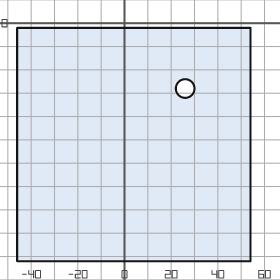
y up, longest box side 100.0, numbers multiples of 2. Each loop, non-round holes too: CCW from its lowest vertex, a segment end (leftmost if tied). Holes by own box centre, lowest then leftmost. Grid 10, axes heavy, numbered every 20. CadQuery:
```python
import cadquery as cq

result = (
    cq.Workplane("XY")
    .moveTo(-46.0, -102.0)
    .lineTo(54.0, -102.0)
    .lineTo(54.0, -2.0)
    .lineTo(-46.0, -2.0)
    .close()
    .moveTo(26.0, -28.0)
    .circle(4.0)
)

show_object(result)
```